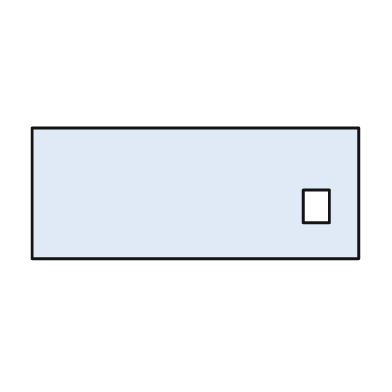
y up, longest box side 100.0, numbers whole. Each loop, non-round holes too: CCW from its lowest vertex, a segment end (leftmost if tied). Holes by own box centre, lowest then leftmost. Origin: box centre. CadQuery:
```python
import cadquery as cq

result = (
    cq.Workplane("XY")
    .moveTo(-50.0, -20.0)
    .lineTo(50.0, -20.0)
    .lineTo(50.0, 20.0)
    .lineTo(-50.0, 20.0)
    .close()
    .moveTo(33.0, -9.0)
    .lineTo(41.0, -9.0)
    .lineTo(41.0, 1.0)
    .lineTo(33.0, 1.0)
    .close()
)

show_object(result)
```